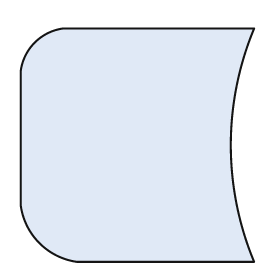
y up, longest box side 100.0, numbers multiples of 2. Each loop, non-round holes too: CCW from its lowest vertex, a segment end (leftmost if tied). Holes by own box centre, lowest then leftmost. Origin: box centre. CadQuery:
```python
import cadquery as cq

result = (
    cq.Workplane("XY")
    .moveTo(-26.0, -50.0)
    .lineTo(50.0, -50.0)
    .threePointArc((40.0, 0.0), (50.0, 50.0))
    .lineTo(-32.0, 50.0)
    .threePointArc((-44.0, 44.0), (-50.0, 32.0))
    .lineTo(-50.0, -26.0)
    .threePointArc((-42.0, -42.0), (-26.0, -50.0))
    .close()
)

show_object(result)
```